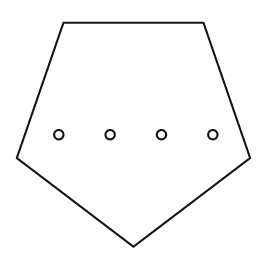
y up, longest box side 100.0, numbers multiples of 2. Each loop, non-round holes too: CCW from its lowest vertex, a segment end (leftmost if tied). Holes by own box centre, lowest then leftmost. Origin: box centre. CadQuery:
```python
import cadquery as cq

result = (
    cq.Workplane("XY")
    .moveTo(0.0, -48.0)
    .lineTo(50.0, -10.0)
    .lineTo(30.0, 48.0)
    .lineTo(-30.0, 48.0)
    .lineTo(-50.0, -10.0)
    .close()
    .moveTo(-32.0, 0.0)
    .circle(2.0)
    .moveTo(-10.0, 0.0)
    .circle(2.0)
    .moveTo(12.0, 0.0)
    .circle(2.0)
    .moveTo(34.0, 0.0)
    .circle(2.0)
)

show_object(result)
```